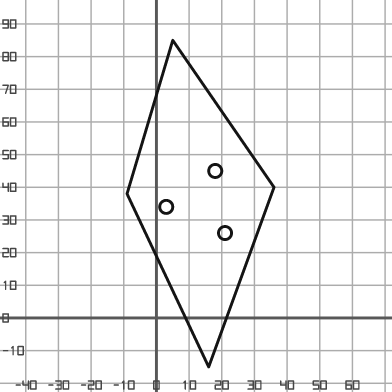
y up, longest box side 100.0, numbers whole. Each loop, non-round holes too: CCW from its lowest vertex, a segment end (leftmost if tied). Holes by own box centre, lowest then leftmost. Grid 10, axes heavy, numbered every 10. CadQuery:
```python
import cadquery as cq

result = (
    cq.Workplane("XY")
    .moveTo(16.0, -15.0)
    .lineTo(36.0, 40.0)
    .lineTo(5.0, 85.0)
    .lineTo(-9.0, 38.0)
    .close()
    .moveTo(21.0, 26.0)
    .circle(2.0)
    .moveTo(3.0, 34.0)
    .circle(2.0)
    .moveTo(18.0, 45.0)
    .circle(2.0)
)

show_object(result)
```